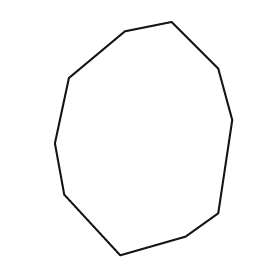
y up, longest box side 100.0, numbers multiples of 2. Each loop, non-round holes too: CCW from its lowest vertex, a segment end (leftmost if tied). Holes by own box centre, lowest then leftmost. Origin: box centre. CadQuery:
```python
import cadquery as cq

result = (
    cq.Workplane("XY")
    .moveTo(-10.0, -50.0)
    .lineTo(18.0, -42.0)
    .lineTo(32.0, -32.0)
    .lineTo(38.0, 8.0)
    .lineTo(32.0, 30.0)
    .lineTo(12.0, 50.0)
    .lineTo(-8.0, 46.0)
    .lineTo(-32.0, 26.0)
    .lineTo(-38.0, -2.0)
    .lineTo(-34.0, -24.0)
    .close()
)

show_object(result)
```